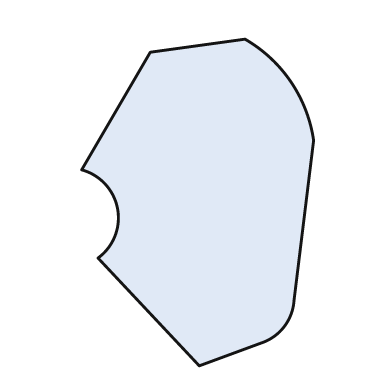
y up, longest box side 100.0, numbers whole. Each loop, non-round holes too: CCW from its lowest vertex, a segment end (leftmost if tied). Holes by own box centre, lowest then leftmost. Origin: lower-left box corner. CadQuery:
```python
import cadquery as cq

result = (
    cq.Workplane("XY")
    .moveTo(36.0, 0.0)
    .lineTo(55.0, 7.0)
    .threePointArc((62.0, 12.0), (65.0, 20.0))
    .lineTo(71.0, 69.0)
    .threePointArc((64.0, 87.0), (50.0, 100.0))
    .lineTo(21.0, 96.0)
    .lineTo(0.0, 60.0)
    .threePointArc((11.0, 48.0), (5.0, 33.0))
    .close()
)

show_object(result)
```